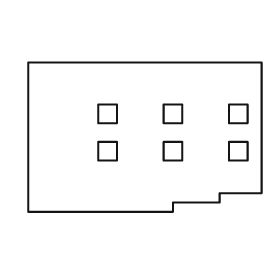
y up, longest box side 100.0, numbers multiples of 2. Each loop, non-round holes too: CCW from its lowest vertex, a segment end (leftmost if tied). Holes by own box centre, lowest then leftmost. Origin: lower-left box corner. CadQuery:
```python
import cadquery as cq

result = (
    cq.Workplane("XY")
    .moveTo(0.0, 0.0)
    .lineTo(62.0, 0.0)
    .lineTo(62.0, 4.0)
    .lineTo(82.0, 4.0)
    .lineTo(82.0, 8.0)
    .lineTo(100.0, 8.0)
    .lineTo(100.0, 64.0)
    .lineTo(0.0, 64.0)
    .close()
    .moveTo(30.0, 22.0)
    .lineTo(38.0, 22.0)
    .lineTo(38.0, 30.0)
    .lineTo(30.0, 30.0)
    .close()
    .moveTo(58.0, 22.0)
    .lineTo(66.0, 22.0)
    .lineTo(66.0, 30.0)
    .lineTo(58.0, 30.0)
    .close()
    .moveTo(86.0, 22.0)
    .lineTo(94.0, 22.0)
    .lineTo(94.0, 30.0)
    .lineTo(86.0, 30.0)
    .close()
    .moveTo(30.0, 38.0)
    .lineTo(38.0, 38.0)
    .lineTo(38.0, 46.0)
    .lineTo(30.0, 46.0)
    .close()
    .moveTo(58.0, 38.0)
    .lineTo(66.0, 38.0)
    .lineTo(66.0, 46.0)
    .lineTo(58.0, 46.0)
    .close()
    .moveTo(86.0, 38.0)
    .lineTo(94.0, 38.0)
    .lineTo(94.0, 46.0)
    .lineTo(86.0, 46.0)
    .close()
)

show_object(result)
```